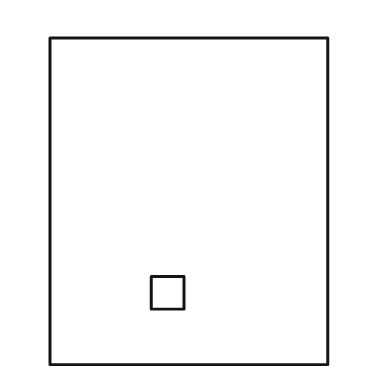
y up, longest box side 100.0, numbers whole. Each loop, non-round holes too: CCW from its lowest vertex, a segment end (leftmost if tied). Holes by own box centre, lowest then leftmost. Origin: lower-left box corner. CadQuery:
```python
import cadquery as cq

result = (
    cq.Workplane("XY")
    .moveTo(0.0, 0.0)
    .lineTo(85.0, 0.0)
    .lineTo(85.0, 100.0)
    .lineTo(0.0, 100.0)
    .close()
    .moveTo(31.0, 17.0)
    .lineTo(41.0, 17.0)
    .lineTo(41.0, 27.0)
    .lineTo(31.0, 27.0)
    .close()
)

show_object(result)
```